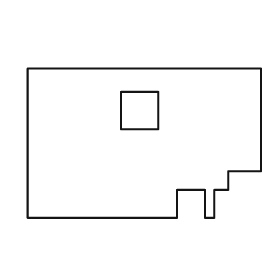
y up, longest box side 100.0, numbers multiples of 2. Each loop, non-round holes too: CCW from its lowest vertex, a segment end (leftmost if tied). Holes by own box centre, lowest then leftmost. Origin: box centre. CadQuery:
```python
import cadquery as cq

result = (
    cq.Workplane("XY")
    .moveTo(-50.0, -32.0)
    .lineTo(14.0, -32.0)
    .lineTo(14.0, -20.0)
    .lineTo(26.0, -20.0)
    .lineTo(26.0, -32.0)
    .lineTo(30.0, -32.0)
    .lineTo(30.0, -20.0)
    .lineTo(36.0, -20.0)
    .lineTo(36.0, -12.0)
    .lineTo(50.0, -12.0)
    .lineTo(50.0, 32.0)
    .lineTo(-50.0, 32.0)
    .close()
    .moveTo(-10.0, 6.0)
    .lineTo(6.0, 6.0)
    .lineTo(6.0, 22.0)
    .lineTo(-10.0, 22.0)
    .close()
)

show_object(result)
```